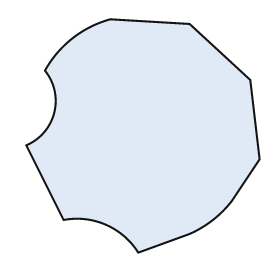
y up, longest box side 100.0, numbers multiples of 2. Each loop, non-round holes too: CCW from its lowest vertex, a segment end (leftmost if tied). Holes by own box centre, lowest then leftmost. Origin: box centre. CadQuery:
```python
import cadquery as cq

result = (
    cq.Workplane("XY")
    .moveTo(-2.0, -50.0)
    .lineTo(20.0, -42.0)
    .threePointArc((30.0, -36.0), (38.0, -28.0))
    .lineTo(50.0, -10.0)
    .lineTo(46.0, 24.0)
    .lineTo(20.0, 48.0)
    .lineTo(-14.0, 50.0)
    .threePointArc((-30.0, 42.0), (-42.0, 28.0))
    .threePointArc((-38.0, 10.0), (-50.0, -4.0))
    .lineTo(-34.0, -36.0)
    .threePointArc((-16.0, -38.0), (-2.0, -50.0))
    .close()
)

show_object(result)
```